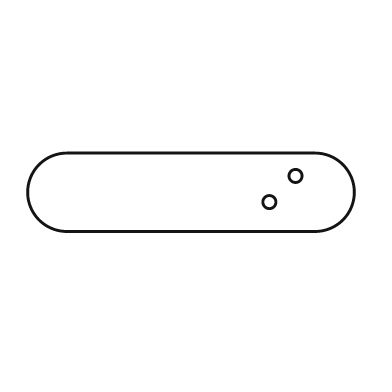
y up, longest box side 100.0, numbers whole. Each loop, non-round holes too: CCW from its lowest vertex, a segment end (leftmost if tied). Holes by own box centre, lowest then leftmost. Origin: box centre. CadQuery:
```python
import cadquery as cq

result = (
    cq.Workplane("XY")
    .moveTo(-38.0, -12.0)
    .lineTo(38.0, -12.0)
    .threePointArc((50.0, 0.0), (38.0, 12.0))
    .lineTo(-38.0, 12.0)
    .threePointArc((-50.0, 0.0), (-38.0, -12.0))
    .close()
    .moveTo(24.0, -3.0)
    .circle(2.0)
    .moveTo(32.0, 5.0)
    .circle(2.0)
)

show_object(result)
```